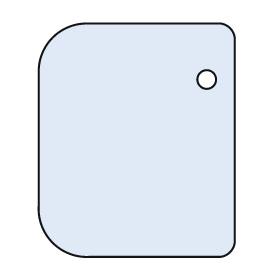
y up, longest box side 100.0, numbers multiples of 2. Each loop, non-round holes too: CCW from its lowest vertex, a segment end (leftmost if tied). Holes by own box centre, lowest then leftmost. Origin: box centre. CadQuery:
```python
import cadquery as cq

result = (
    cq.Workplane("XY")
    .moveTo(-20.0, -50.0)
    .lineTo(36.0, -50.0)
    .threePointArc((40.0, -48.0), (42.0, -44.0))
    .lineTo(42.0, 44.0)
    .threePointArc((40.0, 48.0), (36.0, 50.0))
    .lineTo(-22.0, 50.0)
    .threePointArc((-36.0, 44.0), (-42.0, 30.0))
    .lineTo(-42.0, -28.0)
    .threePointArc((-36.0, -44.0), (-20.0, -50.0))
    .close()
    .moveTo(30.0, 26.0)
    .circle(4.0)
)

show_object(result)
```